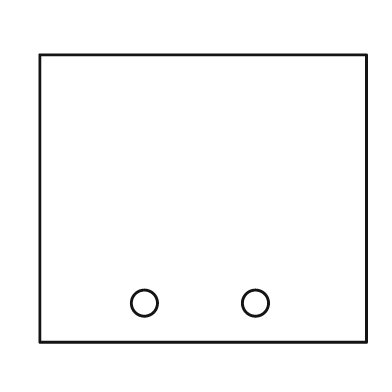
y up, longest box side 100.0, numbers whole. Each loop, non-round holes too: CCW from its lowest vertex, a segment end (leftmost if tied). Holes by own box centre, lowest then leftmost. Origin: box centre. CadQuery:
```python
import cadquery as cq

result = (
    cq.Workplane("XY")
    .moveTo(-50.0, -44.0)
    .lineTo(50.0, -44.0)
    .lineTo(50.0, 44.0)
    .lineTo(-50.0, 44.0)
    .close()
    .moveTo(-18.0, -32.0)
    .circle(4.0)
    .moveTo(16.0, -32.0)
    .circle(4.0)
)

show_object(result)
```